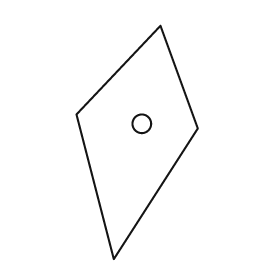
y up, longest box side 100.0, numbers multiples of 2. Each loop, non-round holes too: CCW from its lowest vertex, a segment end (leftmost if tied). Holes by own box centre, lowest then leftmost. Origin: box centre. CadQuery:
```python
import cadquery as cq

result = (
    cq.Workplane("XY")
    .moveTo(-10.0, -50.0)
    .lineTo(26.0, 6.0)
    .lineTo(10.0, 50.0)
    .lineTo(-26.0, 12.0)
    .close()
    .moveTo(2.0, 8.0)
    .circle(4.0)
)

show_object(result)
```